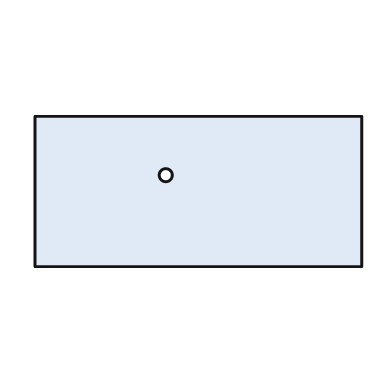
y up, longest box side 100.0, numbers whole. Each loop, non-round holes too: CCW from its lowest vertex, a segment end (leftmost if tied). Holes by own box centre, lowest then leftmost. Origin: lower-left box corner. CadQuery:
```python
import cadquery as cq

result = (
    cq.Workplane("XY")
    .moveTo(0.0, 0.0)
    .lineTo(100.0, 0.0)
    .lineTo(100.0, 46.0)
    .lineTo(0.0, 46.0)
    .close()
    .moveTo(40.0, 28.0)
    .circle(2.0)
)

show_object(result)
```